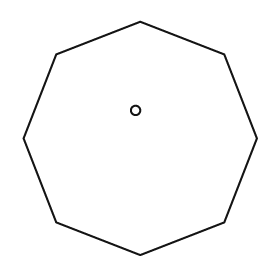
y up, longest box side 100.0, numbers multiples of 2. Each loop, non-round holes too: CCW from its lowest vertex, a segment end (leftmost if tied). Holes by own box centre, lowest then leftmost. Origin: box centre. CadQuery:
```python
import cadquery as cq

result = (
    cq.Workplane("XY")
    .moveTo(0.0, -50.0)
    .lineTo(36.0, -36.0)
    .lineTo(50.0, 0.0)
    .lineTo(36.0, 36.0)
    .lineTo(0.0, 50.0)
    .lineTo(-36.0, 36.0)
    .lineTo(-50.0, 0.0)
    .lineTo(-36.0, -36.0)
    .close()
    .moveTo(-2.0, 12.0)
    .circle(2.0)
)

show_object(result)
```